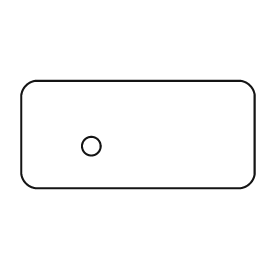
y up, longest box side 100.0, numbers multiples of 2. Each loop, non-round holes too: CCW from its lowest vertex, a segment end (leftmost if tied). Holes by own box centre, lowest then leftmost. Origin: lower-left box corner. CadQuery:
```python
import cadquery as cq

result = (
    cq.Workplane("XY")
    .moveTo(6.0, 0.0)
    .lineTo(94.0, 0.0)
    .threePointArc((98.0, 2.0), (100.0, 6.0))
    .lineTo(100.0, 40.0)
    .threePointArc((98.0, 44.0), (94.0, 46.0))
    .lineTo(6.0, 46.0)
    .threePointArc((2.0, 44.0), (0.0, 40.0))
    .lineTo(0.0, 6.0)
    .threePointArc((2.0, 2.0), (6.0, 0.0))
    .close()
    .moveTo(30.0, 18.0)
    .circle(4.0)
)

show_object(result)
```